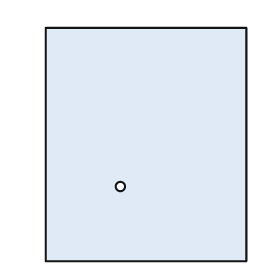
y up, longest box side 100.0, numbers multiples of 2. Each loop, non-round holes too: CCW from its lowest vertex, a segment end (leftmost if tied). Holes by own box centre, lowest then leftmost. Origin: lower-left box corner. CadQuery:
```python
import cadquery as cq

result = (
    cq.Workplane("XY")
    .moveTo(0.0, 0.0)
    .lineTo(86.0, 0.0)
    .lineTo(86.0, 100.0)
    .lineTo(0.0, 100.0)
    .close()
    .moveTo(32.0, 32.0)
    .circle(2.0)
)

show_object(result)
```